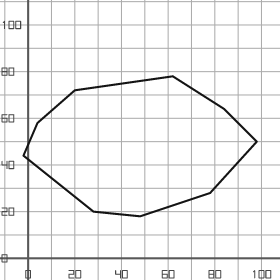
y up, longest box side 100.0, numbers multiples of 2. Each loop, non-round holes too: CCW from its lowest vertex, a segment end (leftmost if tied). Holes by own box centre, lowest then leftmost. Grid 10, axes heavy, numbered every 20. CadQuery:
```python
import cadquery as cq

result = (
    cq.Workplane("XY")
    .moveTo(48.0, 18.0)
    .lineTo(78.0, 28.0)
    .lineTo(98.0, 50.0)
    .lineTo(84.0, 64.0)
    .lineTo(62.0, 78.0)
    .lineTo(20.0, 72.0)
    .lineTo(4.0, 58.0)
    .lineTo(-2.0, 44.0)
    .lineTo(28.0, 20.0)
    .close()
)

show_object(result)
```